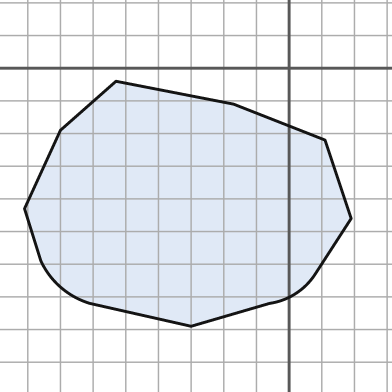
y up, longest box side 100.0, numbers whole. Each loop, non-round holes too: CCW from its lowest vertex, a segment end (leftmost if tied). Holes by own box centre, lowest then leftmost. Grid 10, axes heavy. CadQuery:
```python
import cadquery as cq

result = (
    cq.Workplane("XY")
    .moveTo(-30.0, -79.0)
    .lineTo(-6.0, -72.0)
    .threePointArc((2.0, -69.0), (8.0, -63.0))
    .lineTo(19.0, -46.0)
    .lineTo(11.0, -22.0)
    .lineTo(-17.0, -11.0)
    .lineTo(-53.0, -4.0)
    .lineTo(-70.0, -19.0)
    .lineTo(-81.0, -43.0)
    .lineTo(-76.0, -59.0)
    .threePointArc((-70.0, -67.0), (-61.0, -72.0))
    .close()
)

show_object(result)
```